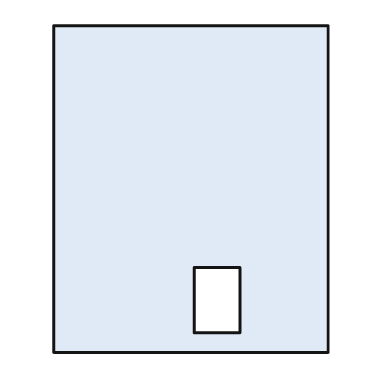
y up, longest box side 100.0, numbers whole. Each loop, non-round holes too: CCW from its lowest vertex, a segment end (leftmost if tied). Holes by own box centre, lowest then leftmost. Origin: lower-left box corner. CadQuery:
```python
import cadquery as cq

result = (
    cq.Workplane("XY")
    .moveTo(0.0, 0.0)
    .lineTo(84.0, 0.0)
    .lineTo(84.0, 100.0)
    .lineTo(0.0, 100.0)
    .close()
    .moveTo(43.0, 6.0)
    .lineTo(57.0, 6.0)
    .lineTo(57.0, 26.0)
    .lineTo(43.0, 26.0)
    .close()
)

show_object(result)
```